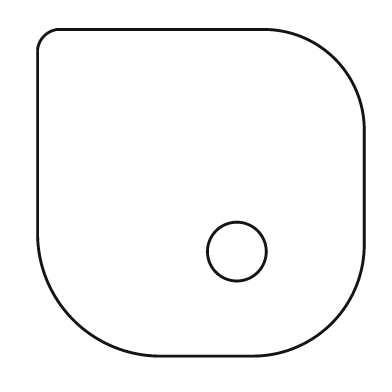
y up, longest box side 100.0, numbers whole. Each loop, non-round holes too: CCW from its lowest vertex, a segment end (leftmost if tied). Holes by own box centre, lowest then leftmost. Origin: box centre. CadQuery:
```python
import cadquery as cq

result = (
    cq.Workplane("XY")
    .moveTo(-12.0, -50.0)
    .lineTo(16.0, -50.0)
    .threePointArc((40.0, -40.0), (50.0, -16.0))
    .lineTo(50.0, 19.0)
    .threePointArc((41.0, 41.0), (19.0, 50.0))
    .lineTo(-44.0, 50.0)
    .threePointArc((-48.0, 48.0), (-50.0, 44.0))
    .lineTo(-50.0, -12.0)
    .threePointArc((-39.0, -39.0), (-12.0, -50.0))
    .close()
    .moveTo(11.0, -18.0)
    .circle(9.0)
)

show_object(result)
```